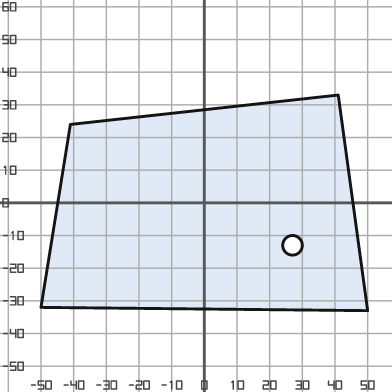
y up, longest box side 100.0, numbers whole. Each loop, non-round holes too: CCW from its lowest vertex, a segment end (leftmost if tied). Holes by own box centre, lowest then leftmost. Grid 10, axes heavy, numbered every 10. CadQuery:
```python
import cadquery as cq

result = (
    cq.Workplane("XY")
    .moveTo(50.0, -33.0)
    .lineTo(41.0, 33.0)
    .lineTo(-41.0, 24.0)
    .lineTo(-50.0, -32.0)
    .close()
    .moveTo(27.0, -13.0)
    .circle(3.0)
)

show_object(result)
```